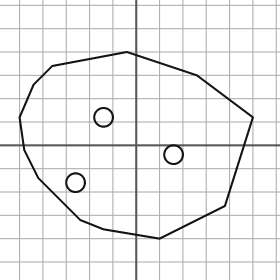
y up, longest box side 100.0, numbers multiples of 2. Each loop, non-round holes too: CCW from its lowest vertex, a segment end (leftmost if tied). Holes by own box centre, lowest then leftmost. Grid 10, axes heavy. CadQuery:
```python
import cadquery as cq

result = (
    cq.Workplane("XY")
    .moveTo(10.0, -40.0)
    .lineTo(38.0, -26.0)
    .lineTo(50.0, 12.0)
    .lineTo(26.0, 30.0)
    .lineTo(-4.0, 40.0)
    .lineTo(-36.0, 34.0)
    .lineTo(-44.0, 26.0)
    .lineTo(-50.0, 12.0)
    .lineTo(-48.0, -2.0)
    .lineTo(-42.0, -14.0)
    .lineTo(-24.0, -32.0)
    .lineTo(-14.0, -36.0)
    .close()
    .moveTo(-26.0, -16.0)
    .circle(4.0)
    .moveTo(16.0, -4.0)
    .circle(4.0)
    .moveTo(-14.0, 12.0)
    .circle(4.0)
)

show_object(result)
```